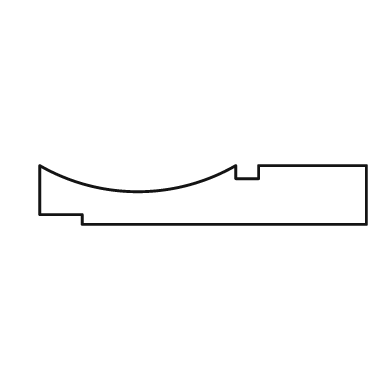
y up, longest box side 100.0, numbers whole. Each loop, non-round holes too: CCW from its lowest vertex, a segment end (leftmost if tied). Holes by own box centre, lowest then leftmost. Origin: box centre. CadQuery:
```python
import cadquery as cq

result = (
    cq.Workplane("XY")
    .moveTo(-37.0, -9.0)
    .lineTo(50.0, -9.0)
    .lineTo(50.0, 9.0)
    .lineTo(17.0, 9.0)
    .lineTo(17.0, 5.0)
    .lineTo(10.0, 5.0)
    .lineTo(10.0, 9.0)
    .threePointArc((-20.0, 1.0), (-50.0, 9.0))
    .lineTo(-50.0, -6.0)
    .lineTo(-37.0, -6.0)
    .close()
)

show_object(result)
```